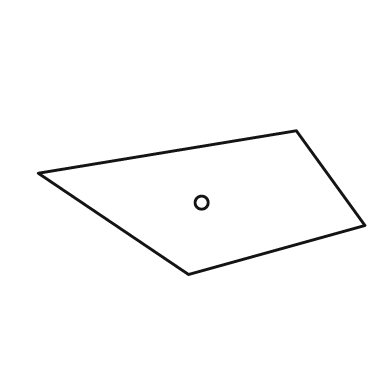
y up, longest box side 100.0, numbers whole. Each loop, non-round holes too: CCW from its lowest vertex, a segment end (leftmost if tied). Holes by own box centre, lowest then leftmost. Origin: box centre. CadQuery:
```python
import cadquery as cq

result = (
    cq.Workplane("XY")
    .moveTo(-4.0, -22.0)
    .lineTo(50.0, -7.0)
    .lineTo(29.0, 22.0)
    .lineTo(-50.0, 9.0)
    .close()
    .moveTo(0.0, 0.0)
    .circle(2.0)
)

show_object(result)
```